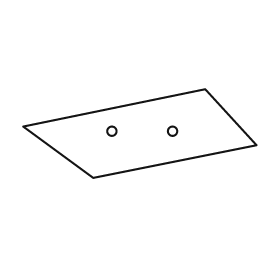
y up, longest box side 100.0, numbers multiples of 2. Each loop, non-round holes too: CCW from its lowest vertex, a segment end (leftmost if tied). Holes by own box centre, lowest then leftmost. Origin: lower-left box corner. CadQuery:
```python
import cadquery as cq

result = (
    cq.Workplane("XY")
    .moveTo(30.0, 0.0)
    .lineTo(100.0, 14.0)
    .lineTo(78.0, 38.0)
    .lineTo(0.0, 22.0)
    .close()
    .moveTo(38.0, 20.0)
    .circle(2.0)
    .moveTo(64.0, 20.0)
    .circle(2.0)
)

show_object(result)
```